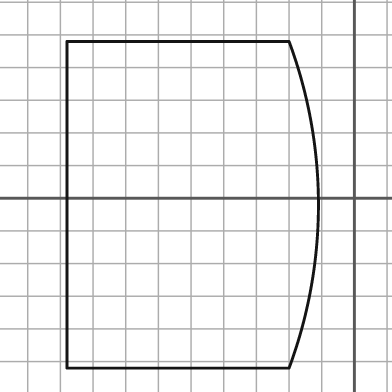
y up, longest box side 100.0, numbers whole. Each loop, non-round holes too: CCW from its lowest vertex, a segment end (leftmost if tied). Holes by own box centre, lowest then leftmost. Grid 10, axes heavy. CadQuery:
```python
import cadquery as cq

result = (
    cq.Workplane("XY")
    .moveTo(-88.0, -52.0)
    .lineTo(-20.0, -52.0)
    .threePointArc((-11.0, -2.0), (-20.0, 48.0))
    .lineTo(-88.0, 48.0)
    .close()
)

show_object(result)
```